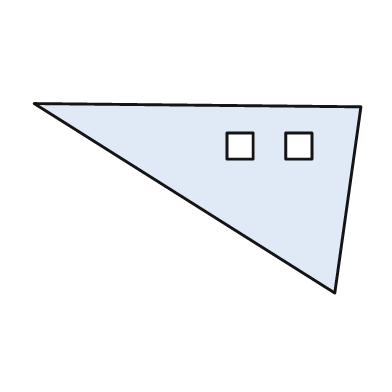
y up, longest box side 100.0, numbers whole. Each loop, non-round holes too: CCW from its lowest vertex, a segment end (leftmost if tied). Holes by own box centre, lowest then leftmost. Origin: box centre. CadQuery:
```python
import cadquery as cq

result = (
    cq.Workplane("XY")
    .moveTo(42.0, -29.0)
    .lineTo(50.0, 28.0)
    .lineTo(-50.0, 29.0)
    .close()
    .moveTo(9.0, 12.0)
    .lineTo(17.0, 12.0)
    .lineTo(17.0, 20.0)
    .lineTo(9.0, 20.0)
    .close()
    .moveTo(27.0, 12.0)
    .lineTo(35.0, 12.0)
    .lineTo(35.0, 20.0)
    .lineTo(27.0, 20.0)
    .close()
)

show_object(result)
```